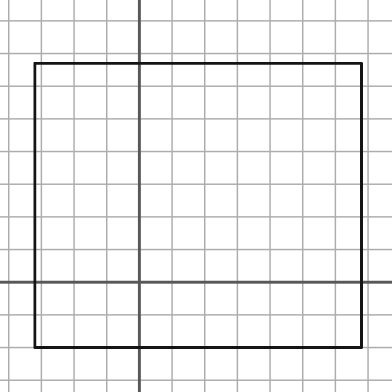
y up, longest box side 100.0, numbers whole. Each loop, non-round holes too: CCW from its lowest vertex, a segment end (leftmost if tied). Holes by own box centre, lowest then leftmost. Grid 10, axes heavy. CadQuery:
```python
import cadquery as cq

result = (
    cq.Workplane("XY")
    .moveTo(-32.0, -20.0)
    .lineTo(68.0, -20.0)
    .lineTo(68.0, 67.0)
    .lineTo(-32.0, 67.0)
    .close()
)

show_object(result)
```